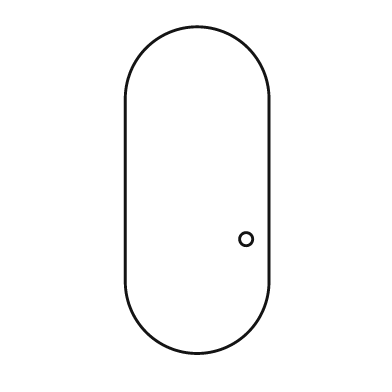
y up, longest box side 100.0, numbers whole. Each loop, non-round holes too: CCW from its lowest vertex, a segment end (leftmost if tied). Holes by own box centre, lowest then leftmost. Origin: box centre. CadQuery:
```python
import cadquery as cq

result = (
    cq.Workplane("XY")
    .moveTo(-22.0, -28.0)
    .threePointArc((0.0, -50.0), (22.0, -28.0))
    .lineTo(22.0, 28.0)
    .threePointArc((0.0, 50.0), (-22.0, 28.0))
    .close()
    .moveTo(15.0, -15.0)
    .circle(2.0)
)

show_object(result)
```